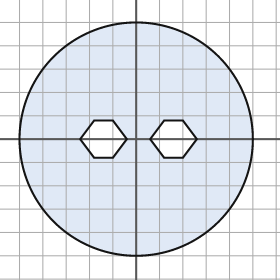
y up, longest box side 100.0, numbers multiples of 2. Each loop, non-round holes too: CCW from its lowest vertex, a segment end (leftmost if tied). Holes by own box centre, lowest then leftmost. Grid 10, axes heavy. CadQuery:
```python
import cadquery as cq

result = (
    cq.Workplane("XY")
    .moveTo(0.0, 0.0)
    .circle(50.0)
    .moveTo(-18.0, -8.0)
    .lineTo(-10.0, -8.0)
    .lineTo(-4.0, 0.0)
    .lineTo(-10.0, 8.0)
    .lineTo(-18.0, 8.0)
    .lineTo(-24.0, 0.0)
    .close()
    .moveTo(12.0, -8.0)
    .lineTo(20.0, -8.0)
    .lineTo(26.0, 0.0)
    .lineTo(20.0, 8.0)
    .lineTo(12.0, 8.0)
    .lineTo(6.0, 0.0)
    .close()
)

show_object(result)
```